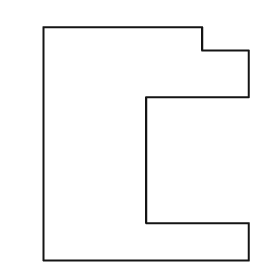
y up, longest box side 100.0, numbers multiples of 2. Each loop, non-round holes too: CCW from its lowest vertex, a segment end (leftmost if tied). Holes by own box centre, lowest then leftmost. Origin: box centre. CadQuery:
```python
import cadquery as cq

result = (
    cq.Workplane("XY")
    .moveTo(-44.0, -50.0)
    .lineTo(44.0, -50.0)
    .lineTo(44.0, -34.0)
    .lineTo(0.0, -34.0)
    .lineTo(0.0, 20.0)
    .lineTo(44.0, 20.0)
    .lineTo(44.0, 40.0)
    .lineTo(24.0, 40.0)
    .lineTo(24.0, 50.0)
    .lineTo(-44.0, 50.0)
    .close()
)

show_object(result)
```